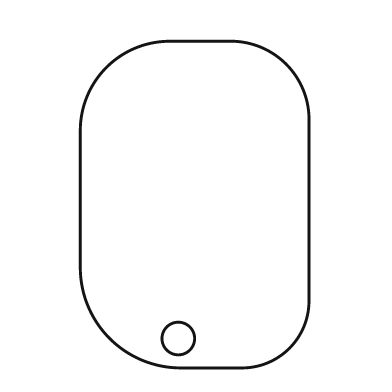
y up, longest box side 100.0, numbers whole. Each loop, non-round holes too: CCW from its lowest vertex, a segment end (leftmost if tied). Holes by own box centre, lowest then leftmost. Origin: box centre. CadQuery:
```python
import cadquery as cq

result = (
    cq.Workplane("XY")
    .moveTo(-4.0, -50.0)
    .lineTo(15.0, -50.0)
    .threePointArc((29.0, -44.0), (35.0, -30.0))
    .lineTo(35.0, 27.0)
    .threePointArc((28.0, 43.0), (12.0, 50.0))
    .lineTo(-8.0, 50.0)
    .threePointArc((-27.0, 42.0), (-35.0, 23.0))
    .lineTo(-35.0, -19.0)
    .threePointArc((-26.0, -41.0), (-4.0, -50.0))
    .close()
    .moveTo(-5.0, -41.0)
    .circle(5.0)
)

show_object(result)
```